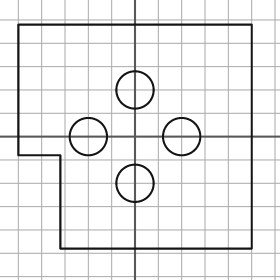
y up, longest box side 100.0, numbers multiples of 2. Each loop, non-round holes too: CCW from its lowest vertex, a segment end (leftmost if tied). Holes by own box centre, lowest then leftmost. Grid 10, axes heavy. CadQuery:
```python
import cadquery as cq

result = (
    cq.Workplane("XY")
    .moveTo(-32.0, -48.0)
    .lineTo(50.0, -48.0)
    .lineTo(50.0, 48.0)
    .lineTo(-50.0, 48.0)
    .lineTo(-50.0, -8.0)
    .lineTo(-32.0, -8.0)
    .close()
    .moveTo(0.0, -20.0)
    .circle(8.0)
    .moveTo(-20.0, 0.0)
    .circle(8.0)
    .moveTo(20.0, 0.0)
    .circle(8.0)
    .moveTo(0.0, 20.0)
    .circle(8.0)
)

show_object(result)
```